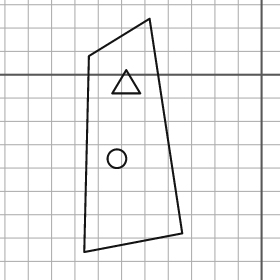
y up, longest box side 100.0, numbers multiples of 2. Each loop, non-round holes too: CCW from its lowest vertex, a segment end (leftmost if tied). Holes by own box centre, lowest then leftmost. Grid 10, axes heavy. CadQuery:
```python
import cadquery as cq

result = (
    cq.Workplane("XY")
    .moveTo(-76.0, -76.0)
    .lineTo(-34.0, -68.0)
    .lineTo(-48.0, 24.0)
    .lineTo(-74.0, 8.0)
    .close()
    .moveTo(-62.0, -36.0)
    .circle(4.0)
    .moveTo(-64.0, -8.0)
    .lineTo(-52.0, -8.0)
    .lineTo(-58.0, 2.0)
    .close()
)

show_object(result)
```